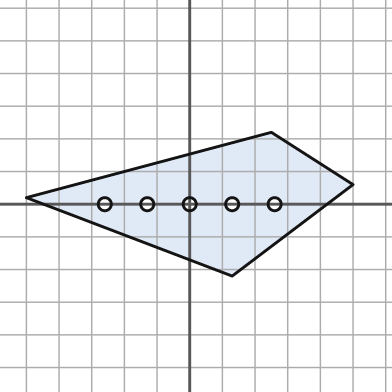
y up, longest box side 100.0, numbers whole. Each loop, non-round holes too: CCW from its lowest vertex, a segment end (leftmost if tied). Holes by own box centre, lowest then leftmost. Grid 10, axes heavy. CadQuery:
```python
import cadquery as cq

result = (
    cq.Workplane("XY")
    .moveTo(13.0, -22.0)
    .lineTo(50.0, 6.0)
    .lineTo(25.0, 22.0)
    .lineTo(-50.0, 2.0)
    .close()
    .moveTo(-26.0, 0.0)
    .circle(2.0)
    .moveTo(-13.0, 0.0)
    .circle(2.0)
    .moveTo(0.0, 0.0)
    .circle(2.0)
    .moveTo(13.0, 0.0)
    .circle(2.0)
    .moveTo(26.0, 0.0)
    .circle(2.0)
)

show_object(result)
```